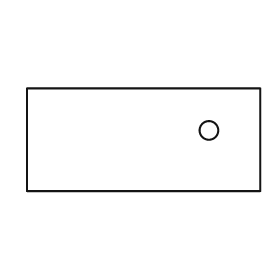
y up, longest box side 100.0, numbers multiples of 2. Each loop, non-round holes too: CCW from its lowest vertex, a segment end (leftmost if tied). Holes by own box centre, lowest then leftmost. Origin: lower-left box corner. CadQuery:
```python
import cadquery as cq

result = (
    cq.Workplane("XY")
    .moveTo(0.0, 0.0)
    .lineTo(100.0, 0.0)
    .lineTo(100.0, 44.0)
    .lineTo(0.0, 44.0)
    .close()
    .moveTo(78.0, 26.0)
    .circle(4.0)
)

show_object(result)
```